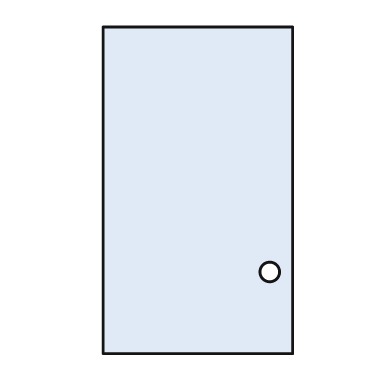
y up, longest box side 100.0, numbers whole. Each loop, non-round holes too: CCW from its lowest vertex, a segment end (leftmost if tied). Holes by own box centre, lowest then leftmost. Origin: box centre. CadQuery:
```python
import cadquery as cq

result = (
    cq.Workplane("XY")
    .moveTo(-29.0, -50.0)
    .lineTo(29.0, -50.0)
    .lineTo(29.0, 50.0)
    .lineTo(-29.0, 50.0)
    .close()
    .moveTo(22.0, -25.0)
    .circle(3.0)
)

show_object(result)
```